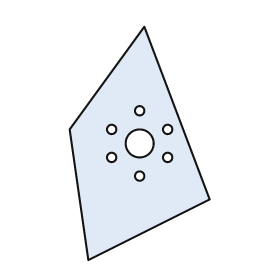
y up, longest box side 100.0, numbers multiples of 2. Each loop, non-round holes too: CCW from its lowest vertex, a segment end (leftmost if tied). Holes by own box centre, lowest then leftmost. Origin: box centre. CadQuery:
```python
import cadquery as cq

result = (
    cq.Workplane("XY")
    .moveTo(-22.0, -50.0)
    .lineTo(30.0, -24.0)
    .lineTo(2.0, 50.0)
    .lineTo(-30.0, 6.0)
    .close()
    .moveTo(0.0, -14.0)
    .circle(2.0)
    .moveTo(-12.0, -6.0)
    .circle(2.0)
    .moveTo(12.0, -6.0)
    .circle(2.0)
    .moveTo(0.0, 0.0)
    .circle(6.0)
    .moveTo(-12.0, 6.0)
    .circle(2.0)
    .moveTo(12.0, 6.0)
    .circle(2.0)
    .moveTo(0.0, 14.0)
    .circle(2.0)
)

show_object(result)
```